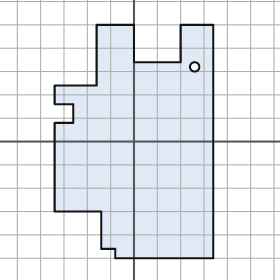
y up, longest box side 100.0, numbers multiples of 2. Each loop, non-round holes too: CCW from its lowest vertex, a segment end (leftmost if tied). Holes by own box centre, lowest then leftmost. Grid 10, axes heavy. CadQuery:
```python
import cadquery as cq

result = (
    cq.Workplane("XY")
    .moveTo(-8.0, -50.0)
    .lineTo(34.0, -50.0)
    .lineTo(34.0, 50.0)
    .lineTo(20.0, 50.0)
    .lineTo(20.0, 34.0)
    .lineTo(0.0, 34.0)
    .lineTo(0.0, 50.0)
    .lineTo(-16.0, 50.0)
    .lineTo(-16.0, 24.0)
    .lineTo(-34.0, 24.0)
    .lineTo(-34.0, 16.0)
    .lineTo(-26.0, 16.0)
    .lineTo(-26.0, 8.0)
    .lineTo(-34.0, 8.0)
    .lineTo(-34.0, -30.0)
    .lineTo(-14.0, -30.0)
    .lineTo(-14.0, -46.0)
    .lineTo(-8.0, -46.0)
    .close()
    .moveTo(26.0, 32.0)
    .circle(2.0)
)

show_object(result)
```